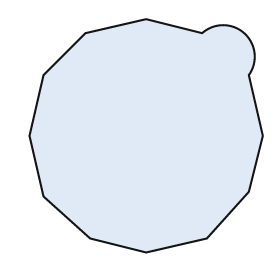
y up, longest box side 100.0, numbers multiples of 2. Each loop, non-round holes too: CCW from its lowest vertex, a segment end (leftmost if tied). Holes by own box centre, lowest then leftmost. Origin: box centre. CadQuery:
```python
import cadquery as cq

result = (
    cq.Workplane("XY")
    .moveTo(0.0, -50.0)
    .lineTo(26.0, -44.0)
    .lineTo(44.0, -24.0)
    .lineTo(50.0, 0.0)
    .lineTo(44.0, 26.0)
    .threePointArc((42.0, 44.0), (24.0, 44.0))
    .lineTo(0.0, 50.0)
    .lineTo(-26.0, 44.0)
    .lineTo(-44.0, 26.0)
    .lineTo(-50.0, 0.0)
    .lineTo(-44.0, -26.0)
    .lineTo(-24.0, -44.0)
    .close()
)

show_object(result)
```